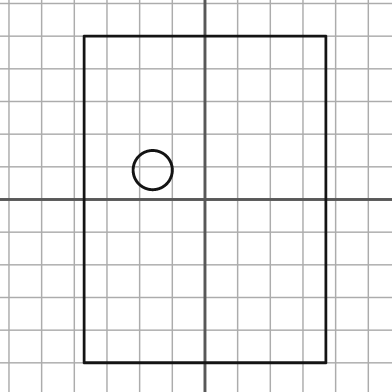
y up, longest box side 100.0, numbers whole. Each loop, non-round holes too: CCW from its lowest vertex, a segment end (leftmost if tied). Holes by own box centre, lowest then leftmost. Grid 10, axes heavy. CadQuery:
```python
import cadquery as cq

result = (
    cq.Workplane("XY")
    .moveTo(-37.0, -50.0)
    .lineTo(37.0, -50.0)
    .lineTo(37.0, 50.0)
    .lineTo(-37.0, 50.0)
    .close()
    .moveTo(-16.0, 9.0)
    .circle(6.0)
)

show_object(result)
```